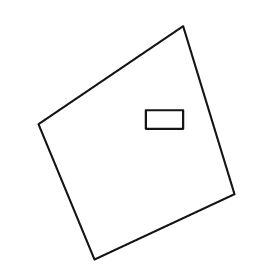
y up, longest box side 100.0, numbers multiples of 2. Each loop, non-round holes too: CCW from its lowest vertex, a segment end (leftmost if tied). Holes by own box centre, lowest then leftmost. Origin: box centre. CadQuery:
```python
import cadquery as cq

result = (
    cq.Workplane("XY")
    .moveTo(-18.0, -50.0)
    .lineTo(42.0, -22.0)
    .lineTo(20.0, 50.0)
    .lineTo(-42.0, 8.0)
    .close()
    .moveTo(4.0, 6.0)
    .lineTo(20.0, 6.0)
    .lineTo(20.0, 14.0)
    .lineTo(4.0, 14.0)
    .close()
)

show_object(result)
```